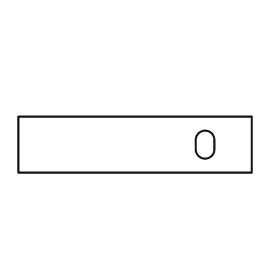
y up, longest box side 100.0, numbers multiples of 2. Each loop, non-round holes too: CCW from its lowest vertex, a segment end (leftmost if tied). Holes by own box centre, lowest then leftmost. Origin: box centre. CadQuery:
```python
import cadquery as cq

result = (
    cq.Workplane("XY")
    .moveTo(-50.0, -12.0)
    .lineTo(50.0, -12.0)
    .lineTo(50.0, 12.0)
    .lineTo(-50.0, 12.0)
    .close()
    .moveTo(26.0, -2.0)
    .threePointArc((30.0, -6.0), (34.0, -2.0))
    .lineTo(34.0, 2.0)
    .threePointArc((30.0, 6.0), (26.0, 2.0))
    .close()
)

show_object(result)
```